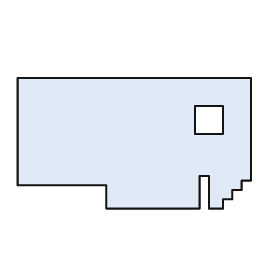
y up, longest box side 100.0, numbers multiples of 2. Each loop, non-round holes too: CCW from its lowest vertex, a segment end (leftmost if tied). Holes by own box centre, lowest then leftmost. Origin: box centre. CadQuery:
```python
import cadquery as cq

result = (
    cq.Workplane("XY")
    .moveTo(-12.0, -28.0)
    .lineTo(28.0, -28.0)
    .lineTo(28.0, -14.0)
    .lineTo(32.0, -14.0)
    .lineTo(32.0, -28.0)
    .lineTo(38.0, -28.0)
    .lineTo(38.0, -24.0)
    .lineTo(42.0, -24.0)
    .lineTo(42.0, -20.0)
    .lineTo(46.0, -20.0)
    .lineTo(46.0, -16.0)
    .lineTo(50.0, -16.0)
    .lineTo(50.0, 28.0)
    .lineTo(-50.0, 28.0)
    .lineTo(-50.0, -18.0)
    .lineTo(-12.0, -18.0)
    .close()
    .moveTo(26.0, 4.0)
    .lineTo(38.0, 4.0)
    .lineTo(38.0, 16.0)
    .lineTo(26.0, 16.0)
    .close()
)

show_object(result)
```